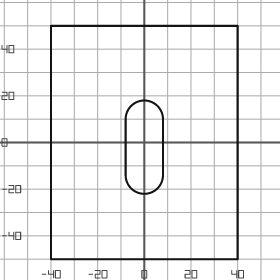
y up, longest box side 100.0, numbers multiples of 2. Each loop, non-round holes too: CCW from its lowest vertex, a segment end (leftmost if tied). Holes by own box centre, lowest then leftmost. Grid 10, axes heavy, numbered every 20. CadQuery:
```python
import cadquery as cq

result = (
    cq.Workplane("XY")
    .moveTo(-40.0, -50.0)
    .lineTo(40.0, -50.0)
    .lineTo(40.0, 50.0)
    .lineTo(-40.0, 50.0)
    .close()
    .moveTo(-8.0, -14.0)
    .threePointArc((0.0, -22.0), (8.0, -14.0))
    .lineTo(8.0, 10.0)
    .threePointArc((0.0, 18.0), (-8.0, 10.0))
    .close()
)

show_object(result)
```